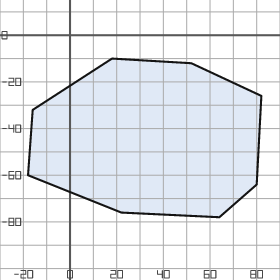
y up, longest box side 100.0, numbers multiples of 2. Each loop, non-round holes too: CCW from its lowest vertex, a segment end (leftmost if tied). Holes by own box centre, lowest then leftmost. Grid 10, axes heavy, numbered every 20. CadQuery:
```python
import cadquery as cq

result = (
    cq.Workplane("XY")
    .moveTo(64.0, -78.0)
    .lineTo(80.0, -64.0)
    .lineTo(82.0, -26.0)
    .lineTo(52.0, -12.0)
    .lineTo(18.0, -10.0)
    .lineTo(-16.0, -32.0)
    .lineTo(-18.0, -60.0)
    .lineTo(22.0, -76.0)
    .close()
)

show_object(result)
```